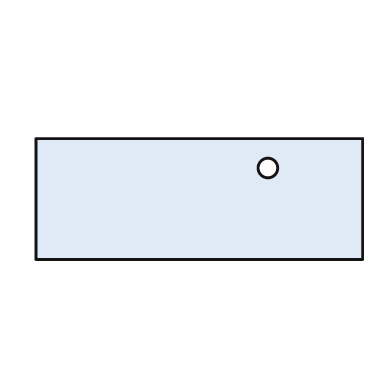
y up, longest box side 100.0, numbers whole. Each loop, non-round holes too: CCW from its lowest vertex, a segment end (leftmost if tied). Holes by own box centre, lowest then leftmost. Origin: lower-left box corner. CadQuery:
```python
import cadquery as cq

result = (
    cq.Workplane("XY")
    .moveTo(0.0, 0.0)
    .lineTo(100.0, 0.0)
    .lineTo(100.0, 37.0)
    .lineTo(0.0, 37.0)
    .close()
    .moveTo(71.0, 28.0)
    .circle(3.0)
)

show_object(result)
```